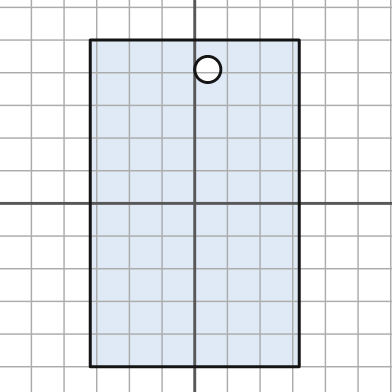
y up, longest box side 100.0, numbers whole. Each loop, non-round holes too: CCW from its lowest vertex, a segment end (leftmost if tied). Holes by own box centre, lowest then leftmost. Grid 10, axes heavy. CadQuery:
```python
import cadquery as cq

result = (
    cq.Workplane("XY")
    .moveTo(-32.0, -50.0)
    .lineTo(32.0, -50.0)
    .lineTo(32.0, 50.0)
    .lineTo(-32.0, 50.0)
    .close()
    .moveTo(4.0, 41.0)
    .circle(4.0)
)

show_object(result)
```